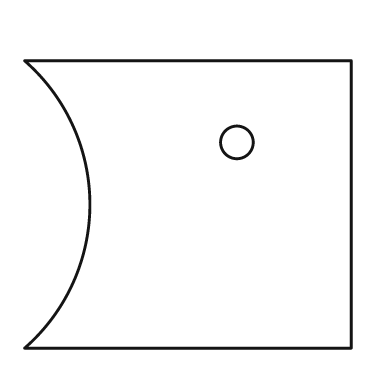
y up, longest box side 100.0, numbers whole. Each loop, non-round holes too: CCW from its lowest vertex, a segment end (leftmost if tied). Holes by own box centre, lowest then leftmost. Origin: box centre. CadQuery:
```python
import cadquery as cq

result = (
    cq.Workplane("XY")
    .moveTo(-50.0, -44.0)
    .lineTo(50.0, -44.0)
    .lineTo(50.0, 44.0)
    .lineTo(-50.0, 44.0)
    .threePointArc((-30.0, 0.0), (-50.0, -44.0))
    .close()
    .moveTo(15.0, 19.0)
    .circle(5.0)
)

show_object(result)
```